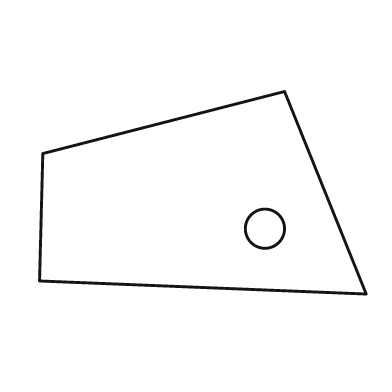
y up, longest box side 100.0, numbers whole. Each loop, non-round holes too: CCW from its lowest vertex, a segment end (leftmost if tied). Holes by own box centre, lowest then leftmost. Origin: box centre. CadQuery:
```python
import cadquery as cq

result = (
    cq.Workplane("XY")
    .moveTo(50.0, -31.0)
    .lineTo(25.0, 31.0)
    .lineTo(-49.0, 12.0)
    .lineTo(-50.0, -27.0)
    .close()
    .moveTo(19.0, -11.0)
    .circle(6.0)
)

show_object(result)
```